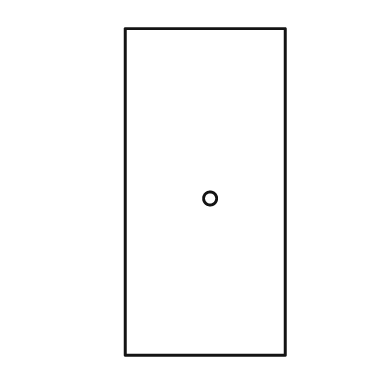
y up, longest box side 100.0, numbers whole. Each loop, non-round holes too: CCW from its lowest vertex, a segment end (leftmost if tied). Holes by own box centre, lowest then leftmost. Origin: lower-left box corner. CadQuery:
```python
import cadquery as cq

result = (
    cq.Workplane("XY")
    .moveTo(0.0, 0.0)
    .lineTo(49.0, 0.0)
    .lineTo(49.0, 100.0)
    .lineTo(0.0, 100.0)
    .close()
    .moveTo(26.0, 48.0)
    .circle(2.0)
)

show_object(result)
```